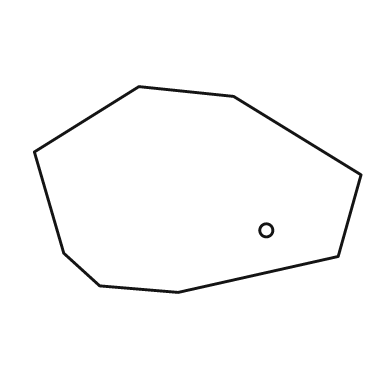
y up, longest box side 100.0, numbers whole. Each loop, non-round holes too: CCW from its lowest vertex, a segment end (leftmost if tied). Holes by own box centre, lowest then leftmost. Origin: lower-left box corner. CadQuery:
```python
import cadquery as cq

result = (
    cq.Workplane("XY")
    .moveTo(44.0, 0.0)
    .lineTo(93.0, 11.0)
    .lineTo(100.0, 36.0)
    .lineTo(61.0, 60.0)
    .lineTo(32.0, 63.0)
    .lineTo(0.0, 43.0)
    .lineTo(9.0, 12.0)
    .lineTo(20.0, 2.0)
    .close()
    .moveTo(71.0, 19.0)
    .circle(2.0)
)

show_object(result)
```